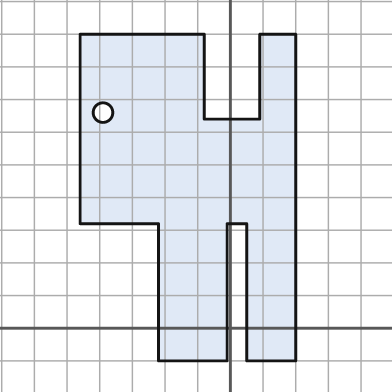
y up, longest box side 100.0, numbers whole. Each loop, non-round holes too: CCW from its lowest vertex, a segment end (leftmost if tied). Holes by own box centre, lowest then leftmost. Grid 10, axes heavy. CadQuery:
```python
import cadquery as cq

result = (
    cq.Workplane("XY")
    .moveTo(-22.0, -10.0)
    .lineTo(-1.0, -10.0)
    .lineTo(-1.0, 32.0)
    .lineTo(5.0, 32.0)
    .lineTo(5.0, -10.0)
    .lineTo(20.0, -10.0)
    .lineTo(20.0, 90.0)
    .lineTo(9.0, 90.0)
    .lineTo(9.0, 64.0)
    .lineTo(-8.0, 64.0)
    .lineTo(-8.0, 90.0)
    .lineTo(-46.0, 90.0)
    .lineTo(-46.0, 32.0)
    .lineTo(-22.0, 32.0)
    .close()
    .moveTo(-39.0, 66.0)
    .circle(3.0)
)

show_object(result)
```